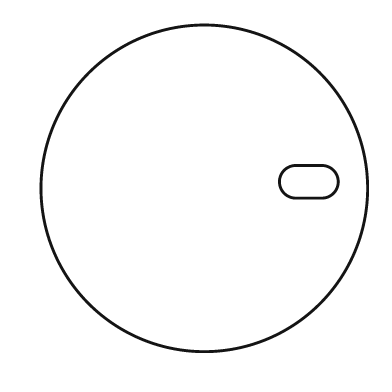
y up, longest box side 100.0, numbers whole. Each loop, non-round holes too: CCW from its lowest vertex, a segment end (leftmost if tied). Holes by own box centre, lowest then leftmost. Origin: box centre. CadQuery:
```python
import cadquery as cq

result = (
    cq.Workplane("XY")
    .moveTo(0.0, 0.0)
    .circle(50.0)
    .moveTo(28.0, -3.0)
    .lineTo(36.0, -3.0)
    .threePointArc((41.0, 2.0), (36.0, 7.0))
    .lineTo(28.0, 7.0)
    .threePointArc((23.0, 2.0), (28.0, -3.0))
    .close()
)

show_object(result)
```